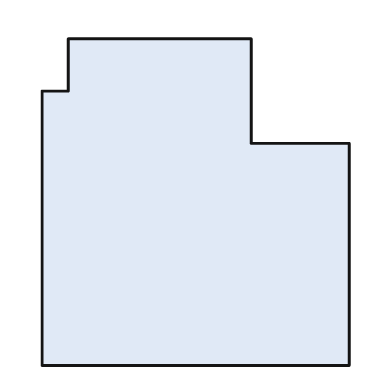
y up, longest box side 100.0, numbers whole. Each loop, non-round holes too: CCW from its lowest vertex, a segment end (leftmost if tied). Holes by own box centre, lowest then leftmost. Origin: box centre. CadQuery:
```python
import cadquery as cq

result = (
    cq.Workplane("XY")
    .moveTo(-47.0, -50.0)
    .lineTo(47.0, -50.0)
    .lineTo(47.0, 18.0)
    .lineTo(17.0, 18.0)
    .lineTo(17.0, 50.0)
    .lineTo(-39.0, 50.0)
    .lineTo(-39.0, 34.0)
    .lineTo(-47.0, 34.0)
    .close()
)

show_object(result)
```